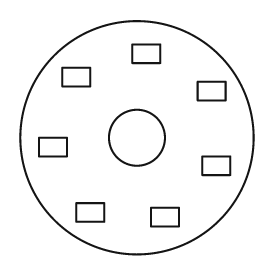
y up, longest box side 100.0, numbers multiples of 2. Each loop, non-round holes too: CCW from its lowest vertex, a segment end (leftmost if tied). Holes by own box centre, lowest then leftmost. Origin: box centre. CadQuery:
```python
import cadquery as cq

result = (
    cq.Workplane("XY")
    .moveTo(0.0, 0.0)
    .circle(50.0)
    .moveTo(6.0, -38.0)
    .lineTo(18.0, -38.0)
    .lineTo(18.0, -30.0)
    .lineTo(6.0, -30.0)
    .close()
    .moveTo(-26.0, -36.0)
    .lineTo(-14.0, -36.0)
    .lineTo(-14.0, -28.0)
    .lineTo(-26.0, -28.0)
    .close()
    .moveTo(28.0, -16.0)
    .lineTo(40.0, -16.0)
    .lineTo(40.0, -8.0)
    .lineTo(28.0, -8.0)
    .close()
    .moveTo(-42.0, -8.0)
    .lineTo(-30.0, -8.0)
    .lineTo(-30.0, 0.0)
    .lineTo(-42.0, 0.0)
    .close()
    .moveTo(0.0, 0.0)
    .circle(12.0)
    .moveTo(26.0, 16.0)
    .lineTo(38.0, 16.0)
    .lineTo(38.0, 24.0)
    .lineTo(26.0, 24.0)
    .close()
    .moveTo(-32.0, 22.0)
    .lineTo(-20.0, 22.0)
    .lineTo(-20.0, 30.0)
    .lineTo(-32.0, 30.0)
    .close()
    .moveTo(-2.0, 32.0)
    .lineTo(10.0, 32.0)
    .lineTo(10.0, 40.0)
    .lineTo(-2.0, 40.0)
    .close()
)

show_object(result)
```